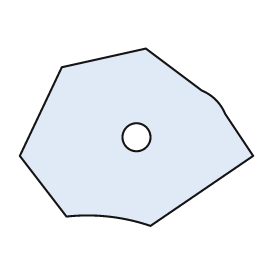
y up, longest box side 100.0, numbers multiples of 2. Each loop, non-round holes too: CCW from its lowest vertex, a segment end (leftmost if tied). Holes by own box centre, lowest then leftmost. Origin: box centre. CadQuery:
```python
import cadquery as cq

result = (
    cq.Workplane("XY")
    .moveTo(6.0, -38.0)
    .lineTo(50.0, -8.0)
    .lineTo(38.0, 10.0)
    .threePointArc((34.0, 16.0), (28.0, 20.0))
    .lineTo(4.0, 38.0)
    .lineTo(-32.0, 30.0)
    .lineTo(-50.0, -8.0)
    .lineTo(-30.0, -34.0)
    .threePointArc((-12.0, -34.0), (6.0, -38.0))
    .close()
    .moveTo(0.0, 0.0)
    .circle(6.0)
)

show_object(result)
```